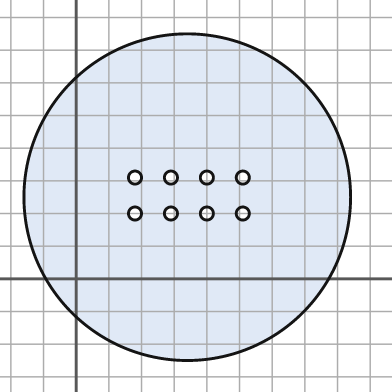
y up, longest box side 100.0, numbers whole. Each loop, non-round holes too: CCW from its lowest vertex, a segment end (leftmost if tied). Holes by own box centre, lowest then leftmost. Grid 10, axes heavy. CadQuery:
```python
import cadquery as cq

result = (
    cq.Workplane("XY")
    .moveTo(34.0, 25.0)
    .circle(50.0)
    .moveTo(18.0, 20.0)
    .circle(2.0)
    .moveTo(29.0, 20.0)
    .circle(2.0)
    .moveTo(40.0, 20.0)
    .circle(2.0)
    .moveTo(51.0, 20.0)
    .circle(2.0)
    .moveTo(18.0, 31.0)
    .circle(2.0)
    .moveTo(29.0, 31.0)
    .circle(2.0)
    .moveTo(40.0, 31.0)
    .circle(2.0)
    .moveTo(51.0, 31.0)
    .circle(2.0)
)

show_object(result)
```